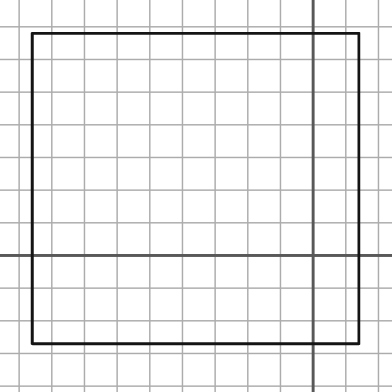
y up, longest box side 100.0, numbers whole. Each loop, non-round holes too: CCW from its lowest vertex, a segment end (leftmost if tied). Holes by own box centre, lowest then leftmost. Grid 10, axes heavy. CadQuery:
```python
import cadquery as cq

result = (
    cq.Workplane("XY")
    .moveTo(-86.0, -27.0)
    .lineTo(14.0, -27.0)
    .lineTo(14.0, 68.0)
    .lineTo(-86.0, 68.0)
    .close()
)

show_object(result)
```